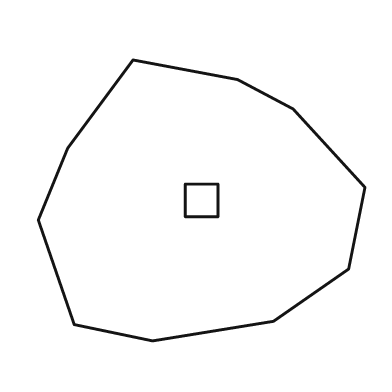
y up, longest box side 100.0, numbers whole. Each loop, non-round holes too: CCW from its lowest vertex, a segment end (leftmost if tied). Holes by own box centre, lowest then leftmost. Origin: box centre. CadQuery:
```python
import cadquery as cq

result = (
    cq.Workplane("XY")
    .moveTo(-15.0, -43.0)
    .lineTo(22.0, -37.0)
    .lineTo(45.0, -21.0)
    .lineTo(50.0, 4.0)
    .lineTo(28.0, 28.0)
    .lineTo(11.0, 37.0)
    .lineTo(-21.0, 43.0)
    .lineTo(-41.0, 16.0)
    .lineTo(-50.0, -6.0)
    .lineTo(-39.0, -38.0)
    .close()
    .moveTo(-5.0, -5.0)
    .lineTo(5.0, -5.0)
    .lineTo(5.0, 5.0)
    .lineTo(-5.0, 5.0)
    .close()
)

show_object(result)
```